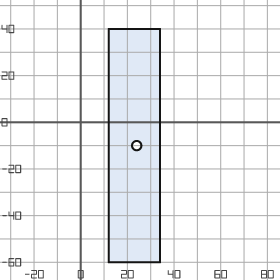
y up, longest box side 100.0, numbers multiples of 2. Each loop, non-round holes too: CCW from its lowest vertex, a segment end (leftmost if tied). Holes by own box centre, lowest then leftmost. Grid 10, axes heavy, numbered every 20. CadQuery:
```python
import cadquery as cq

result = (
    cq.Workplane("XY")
    .moveTo(12.0, -60.0)
    .lineTo(34.0, -60.0)
    .lineTo(34.0, 40.0)
    .lineTo(12.0, 40.0)
    .close()
    .moveTo(24.0, -10.0)
    .circle(2.0)
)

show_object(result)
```